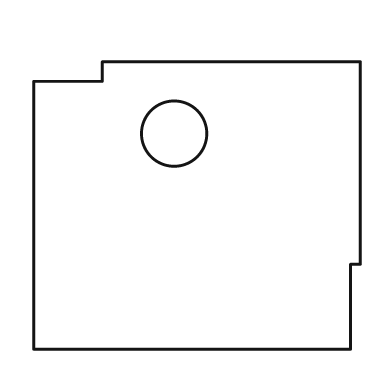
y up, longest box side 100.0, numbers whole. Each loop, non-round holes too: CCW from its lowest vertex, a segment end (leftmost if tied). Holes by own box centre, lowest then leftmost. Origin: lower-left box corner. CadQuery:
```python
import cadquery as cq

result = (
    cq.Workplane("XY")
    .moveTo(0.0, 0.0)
    .lineTo(97.0, 0.0)
    .lineTo(97.0, 26.0)
    .lineTo(100.0, 26.0)
    .lineTo(100.0, 88.0)
    .lineTo(21.0, 88.0)
    .lineTo(21.0, 82.0)
    .lineTo(0.0, 82.0)
    .close()
    .moveTo(43.0, 66.0)
    .circle(10.0)
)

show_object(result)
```